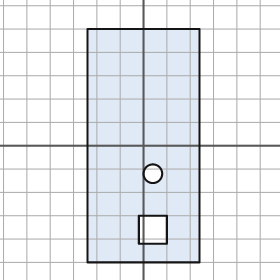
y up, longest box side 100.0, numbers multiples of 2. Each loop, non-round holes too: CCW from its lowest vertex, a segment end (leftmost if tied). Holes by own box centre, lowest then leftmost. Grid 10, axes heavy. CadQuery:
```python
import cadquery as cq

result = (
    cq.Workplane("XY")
    .moveTo(-24.0, -50.0)
    .lineTo(24.0, -50.0)
    .lineTo(24.0, 50.0)
    .lineTo(-24.0, 50.0)
    .close()
    .moveTo(-2.0, -42.0)
    .lineTo(10.0, -42.0)
    .lineTo(10.0, -30.0)
    .lineTo(-2.0, -30.0)
    .close()
    .moveTo(4.0, -12.0)
    .circle(4.0)
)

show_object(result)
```